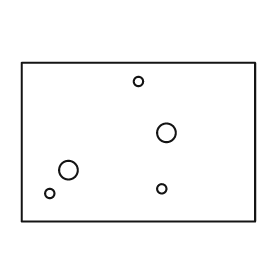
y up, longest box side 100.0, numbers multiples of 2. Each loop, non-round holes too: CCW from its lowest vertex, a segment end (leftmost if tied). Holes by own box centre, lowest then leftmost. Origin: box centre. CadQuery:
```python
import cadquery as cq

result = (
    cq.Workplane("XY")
    .moveTo(-50.0, -34.0)
    .lineTo(50.0, -34.0)
    .lineTo(50.0, 34.0)
    .lineTo(-50.0, 34.0)
    .close()
    .moveTo(-38.0, -22.0)
    .circle(2.0)
    .moveTo(10.0, -20.0)
    .circle(2.0)
    .moveTo(-30.0, -12.0)
    .circle(4.0)
    .moveTo(12.0, 4.0)
    .circle(4.0)
    .moveTo(0.0, 26.0)
    .circle(2.0)
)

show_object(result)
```